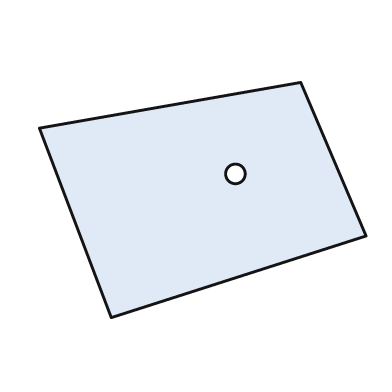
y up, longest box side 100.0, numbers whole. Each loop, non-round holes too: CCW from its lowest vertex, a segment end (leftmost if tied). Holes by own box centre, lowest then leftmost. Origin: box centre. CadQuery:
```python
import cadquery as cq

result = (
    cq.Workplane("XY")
    .moveTo(-28.0, -36.0)
    .lineTo(50.0, -11.0)
    .lineTo(30.0, 36.0)
    .lineTo(-50.0, 22.0)
    .close()
    .moveTo(10.0, 8.0)
    .circle(3.0)
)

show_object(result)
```